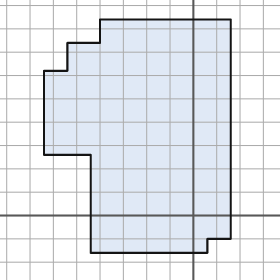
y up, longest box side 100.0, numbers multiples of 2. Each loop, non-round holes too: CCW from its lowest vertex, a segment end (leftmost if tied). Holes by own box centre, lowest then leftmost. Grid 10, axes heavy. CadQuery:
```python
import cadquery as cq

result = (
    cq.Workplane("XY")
    .moveTo(-44.0, -16.0)
    .lineTo(6.0, -16.0)
    .lineTo(6.0, -10.0)
    .lineTo(16.0, -10.0)
    .lineTo(16.0, 84.0)
    .lineTo(-40.0, 84.0)
    .lineTo(-40.0, 74.0)
    .lineTo(-54.0, 74.0)
    .lineTo(-54.0, 62.0)
    .lineTo(-64.0, 62.0)
    .lineTo(-64.0, 26.0)
    .lineTo(-44.0, 26.0)
    .close()
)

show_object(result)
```